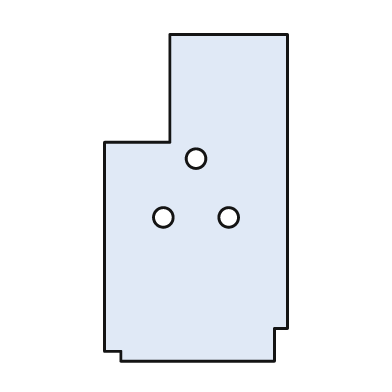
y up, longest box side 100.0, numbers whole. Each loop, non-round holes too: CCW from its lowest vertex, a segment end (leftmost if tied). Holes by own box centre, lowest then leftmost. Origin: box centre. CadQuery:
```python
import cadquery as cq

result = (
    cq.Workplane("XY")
    .moveTo(-23.0, -50.0)
    .lineTo(24.0, -50.0)
    .lineTo(24.0, -40.0)
    .lineTo(28.0, -40.0)
    .lineTo(28.0, 50.0)
    .lineTo(-8.0, 50.0)
    .lineTo(-8.0, 17.0)
    .lineTo(-28.0, 17.0)
    .lineTo(-28.0, -47.0)
    .lineTo(-23.0, -47.0)
    .close()
    .moveTo(-10.0, -6.0)
    .circle(3.0)
    .moveTo(10.0, -6.0)
    .circle(3.0)
    .moveTo(0.0, 12.0)
    .circle(3.0)
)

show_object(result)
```